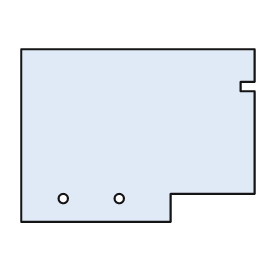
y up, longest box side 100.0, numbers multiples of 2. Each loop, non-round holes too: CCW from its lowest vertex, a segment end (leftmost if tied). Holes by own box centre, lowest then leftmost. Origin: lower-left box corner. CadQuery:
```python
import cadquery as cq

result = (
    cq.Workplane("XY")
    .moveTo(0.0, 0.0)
    .lineTo(64.0, 0.0)
    .lineTo(64.0, 12.0)
    .lineTo(100.0, 12.0)
    .lineTo(100.0, 56.0)
    .lineTo(94.0, 56.0)
    .lineTo(94.0, 60.0)
    .lineTo(100.0, 60.0)
    .lineTo(100.0, 74.0)
    .lineTo(0.0, 74.0)
    .close()
    .moveTo(18.0, 10.0)
    .circle(2.0)
    .moveTo(42.0, 10.0)
    .circle(2.0)
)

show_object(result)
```